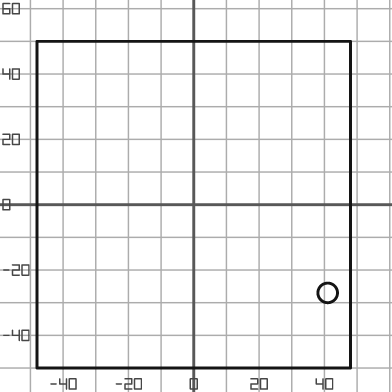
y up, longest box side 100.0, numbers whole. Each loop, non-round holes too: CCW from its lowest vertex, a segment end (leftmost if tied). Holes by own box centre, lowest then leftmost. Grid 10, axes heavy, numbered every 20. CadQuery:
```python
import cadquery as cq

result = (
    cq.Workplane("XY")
    .moveTo(-48.0, -50.0)
    .lineTo(48.0, -50.0)
    .lineTo(48.0, 50.0)
    .lineTo(-48.0, 50.0)
    .close()
    .moveTo(41.0, -27.0)
    .circle(3.0)
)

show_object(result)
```